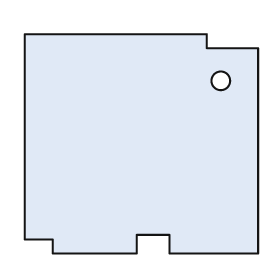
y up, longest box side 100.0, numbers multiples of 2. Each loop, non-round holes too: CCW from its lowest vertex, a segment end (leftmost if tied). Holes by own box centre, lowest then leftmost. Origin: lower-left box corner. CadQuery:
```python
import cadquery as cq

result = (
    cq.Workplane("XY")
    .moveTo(12.0, 0.0)
    .lineTo(48.0, 0.0)
    .lineTo(48.0, 8.0)
    .lineTo(62.0, 8.0)
    .lineTo(62.0, 0.0)
    .lineTo(100.0, 0.0)
    .lineTo(100.0, 88.0)
    .lineTo(78.0, 88.0)
    .lineTo(78.0, 94.0)
    .lineTo(0.0, 94.0)
    .lineTo(0.0, 6.0)
    .lineTo(12.0, 6.0)
    .close()
    .moveTo(84.0, 74.0)
    .circle(4.0)
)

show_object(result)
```